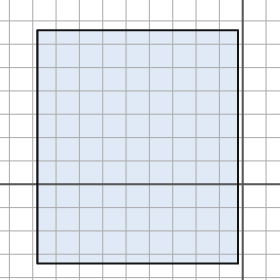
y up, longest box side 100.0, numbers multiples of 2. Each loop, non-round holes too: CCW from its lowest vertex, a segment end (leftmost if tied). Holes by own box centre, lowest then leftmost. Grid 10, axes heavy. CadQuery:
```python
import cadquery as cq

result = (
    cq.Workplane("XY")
    .moveTo(-88.0, -34.0)
    .lineTo(-2.0, -34.0)
    .lineTo(-2.0, 66.0)
    .lineTo(-88.0, 66.0)
    .close()
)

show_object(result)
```